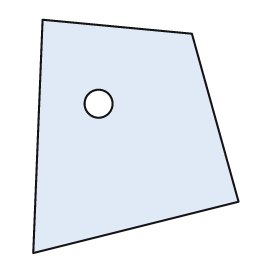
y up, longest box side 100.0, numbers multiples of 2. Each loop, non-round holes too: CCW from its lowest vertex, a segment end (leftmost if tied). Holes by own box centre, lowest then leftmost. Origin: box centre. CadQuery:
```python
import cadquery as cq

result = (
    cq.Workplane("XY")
    .moveTo(-44.0, -50.0)
    .lineTo(44.0, -28.0)
    .lineTo(24.0, 44.0)
    .lineTo(-40.0, 50.0)
    .close()
    .moveTo(-16.0, 14.0)
    .circle(6.0)
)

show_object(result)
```